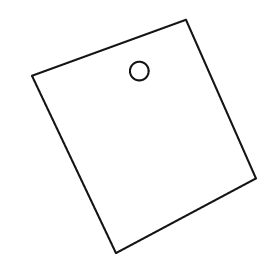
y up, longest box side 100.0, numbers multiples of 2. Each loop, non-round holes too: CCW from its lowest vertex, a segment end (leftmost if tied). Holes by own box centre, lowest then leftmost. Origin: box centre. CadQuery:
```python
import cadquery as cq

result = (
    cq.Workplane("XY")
    .moveTo(-12.0, -50.0)
    .lineTo(48.0, -18.0)
    .lineTo(18.0, 50.0)
    .lineTo(-48.0, 26.0)
    .close()
    .moveTo(-2.0, 28.0)
    .circle(4.0)
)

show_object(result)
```